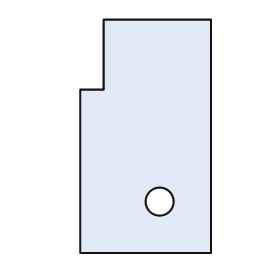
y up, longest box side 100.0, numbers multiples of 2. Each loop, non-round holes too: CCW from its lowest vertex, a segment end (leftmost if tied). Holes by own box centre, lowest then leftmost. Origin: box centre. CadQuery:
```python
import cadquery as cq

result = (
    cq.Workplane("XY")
    .moveTo(-28.0, -50.0)
    .lineTo(28.0, -50.0)
    .lineTo(28.0, 50.0)
    .lineTo(-18.0, 50.0)
    .lineTo(-18.0, 20.0)
    .lineTo(-28.0, 20.0)
    .close()
    .moveTo(6.0, -28.0)
    .circle(6.0)
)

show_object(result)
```